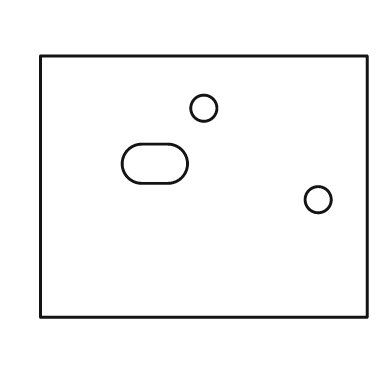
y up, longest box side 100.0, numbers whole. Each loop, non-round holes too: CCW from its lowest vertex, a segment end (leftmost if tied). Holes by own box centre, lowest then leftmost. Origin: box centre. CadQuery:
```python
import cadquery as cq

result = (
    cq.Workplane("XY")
    .moveTo(-50.0, -40.0)
    .lineTo(50.0, -40.0)
    .lineTo(50.0, 40.0)
    .lineTo(-50.0, 40.0)
    .close()
    .moveTo(35.0, -4.0)
    .circle(4.0)
    .moveTo(-19.0, 1.0)
    .lineTo(-11.0, 1.0)
    .threePointArc((-5.0, 7.0), (-11.0, 13.0))
    .lineTo(-19.0, 13.0)
    .threePointArc((-25.0, 7.0), (-19.0, 1.0))
    .close()
    .moveTo(0.0, 24.0)
    .circle(4.0)
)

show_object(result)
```